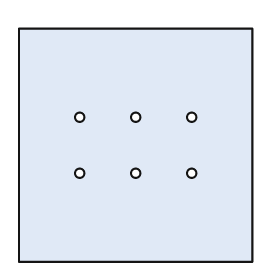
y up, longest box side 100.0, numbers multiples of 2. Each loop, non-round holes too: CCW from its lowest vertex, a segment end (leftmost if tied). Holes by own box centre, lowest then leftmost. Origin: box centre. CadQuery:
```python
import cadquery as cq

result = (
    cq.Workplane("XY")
    .moveTo(-50.0, -50.0)
    .lineTo(50.0, -50.0)
    .lineTo(50.0, 50.0)
    .lineTo(-50.0, 50.0)
    .close()
    .moveTo(-24.0, -12.0)
    .circle(2.0)
    .moveTo(0.0, -12.0)
    .circle(2.0)
    .moveTo(24.0, -12.0)
    .circle(2.0)
    .moveTo(-24.0, 12.0)
    .circle(2.0)
    .moveTo(0.0, 12.0)
    .circle(2.0)
    .moveTo(24.0, 12.0)
    .circle(2.0)
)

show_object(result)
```